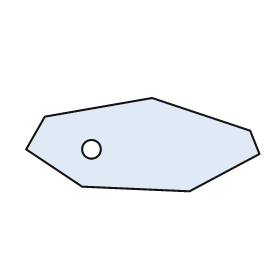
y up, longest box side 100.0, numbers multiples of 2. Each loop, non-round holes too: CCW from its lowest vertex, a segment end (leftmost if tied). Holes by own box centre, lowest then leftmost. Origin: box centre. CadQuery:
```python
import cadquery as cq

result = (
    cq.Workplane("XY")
    .moveTo(20.0, -20.0)
    .lineTo(50.0, -4.0)
    .lineTo(46.0, 6.0)
    .lineTo(4.0, 20.0)
    .lineTo(-42.0, 12.0)
    .lineTo(-50.0, -2.0)
    .lineTo(-26.0, -18.0)
    .close()
    .moveTo(-22.0, -2.0)
    .circle(4.0)
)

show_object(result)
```